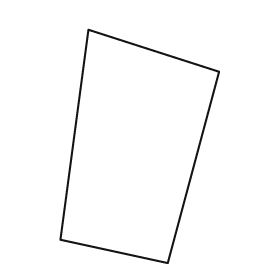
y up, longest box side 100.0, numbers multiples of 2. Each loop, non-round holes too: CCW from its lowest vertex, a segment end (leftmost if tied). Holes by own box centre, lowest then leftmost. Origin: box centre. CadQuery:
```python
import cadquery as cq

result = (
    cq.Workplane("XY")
    .moveTo(12.0, -50.0)
    .lineTo(34.0, 32.0)
    .lineTo(-22.0, 50.0)
    .lineTo(-34.0, -40.0)
    .close()
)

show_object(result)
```